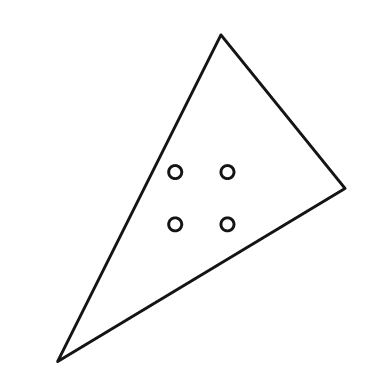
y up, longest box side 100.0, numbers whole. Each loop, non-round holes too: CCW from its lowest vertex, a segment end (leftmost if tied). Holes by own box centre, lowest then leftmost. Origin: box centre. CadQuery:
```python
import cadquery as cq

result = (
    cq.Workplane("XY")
    .moveTo(-44.0, -50.0)
    .lineTo(44.0, 3.0)
    .lineTo(6.0, 50.0)
    .close()
    .moveTo(-8.0, -8.0)
    .circle(2.0)
    .moveTo(8.0, -8.0)
    .circle(2.0)
    .moveTo(-8.0, 8.0)
    .circle(2.0)
    .moveTo(8.0, 8.0)
    .circle(2.0)
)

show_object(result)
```